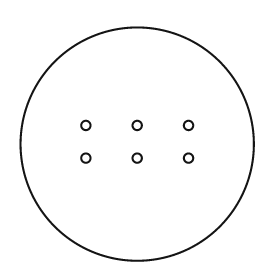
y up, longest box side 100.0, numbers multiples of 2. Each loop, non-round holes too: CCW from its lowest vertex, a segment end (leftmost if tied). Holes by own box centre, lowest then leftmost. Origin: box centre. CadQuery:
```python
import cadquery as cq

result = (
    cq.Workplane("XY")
    .moveTo(0.0, 0.0)
    .circle(50.0)
    .moveTo(-22.0, -6.0)
    .circle(2.0)
    .moveTo(0.0, -6.0)
    .circle(2.0)
    .moveTo(22.0, -6.0)
    .circle(2.0)
    .moveTo(-22.0, 8.0)
    .circle(2.0)
    .moveTo(0.0, 8.0)
    .circle(2.0)
    .moveTo(22.0, 8.0)
    .circle(2.0)
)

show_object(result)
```